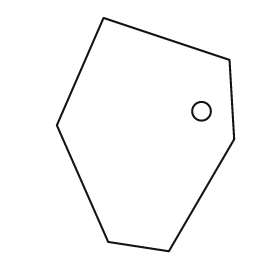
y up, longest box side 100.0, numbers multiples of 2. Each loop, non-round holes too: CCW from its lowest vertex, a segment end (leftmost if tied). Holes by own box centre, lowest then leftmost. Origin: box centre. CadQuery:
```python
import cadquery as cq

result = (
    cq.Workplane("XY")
    .moveTo(10.0, -50.0)
    .lineTo(38.0, -2.0)
    .lineTo(36.0, 32.0)
    .lineTo(-18.0, 50.0)
    .lineTo(-38.0, 4.0)
    .lineTo(-16.0, -46.0)
    .close()
    .moveTo(24.0, 10.0)
    .circle(4.0)
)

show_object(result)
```